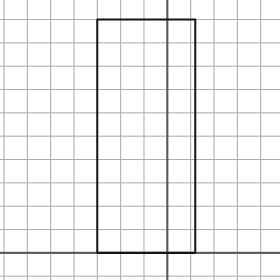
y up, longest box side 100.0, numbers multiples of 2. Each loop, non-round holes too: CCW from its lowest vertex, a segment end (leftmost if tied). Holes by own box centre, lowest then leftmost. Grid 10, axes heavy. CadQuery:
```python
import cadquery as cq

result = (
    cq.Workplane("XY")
    .moveTo(-30.0, 0.0)
    .lineTo(12.0, 0.0)
    .lineTo(12.0, 100.0)
    .lineTo(-30.0, 100.0)
    .close()
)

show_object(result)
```